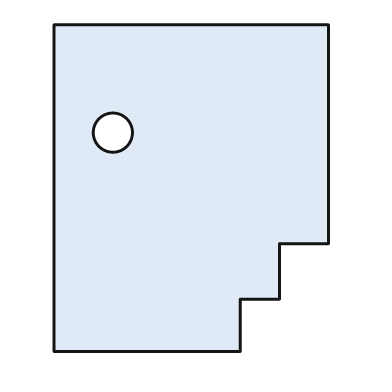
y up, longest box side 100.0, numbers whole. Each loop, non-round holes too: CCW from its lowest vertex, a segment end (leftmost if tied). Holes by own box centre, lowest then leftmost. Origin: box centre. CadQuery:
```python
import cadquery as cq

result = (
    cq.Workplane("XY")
    .moveTo(-42.0, -50.0)
    .lineTo(15.0, -50.0)
    .lineTo(15.0, -34.0)
    .lineTo(27.0, -34.0)
    .lineTo(27.0, -17.0)
    .lineTo(42.0, -17.0)
    .lineTo(42.0, 50.0)
    .lineTo(-42.0, 50.0)
    .close()
    .moveTo(-24.0, 17.0)
    .circle(6.0)
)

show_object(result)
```